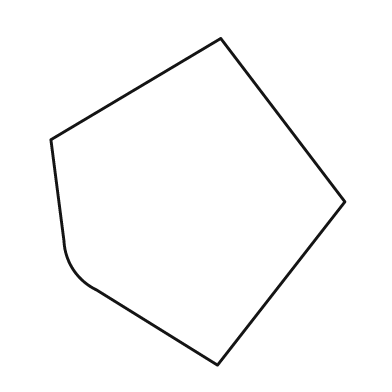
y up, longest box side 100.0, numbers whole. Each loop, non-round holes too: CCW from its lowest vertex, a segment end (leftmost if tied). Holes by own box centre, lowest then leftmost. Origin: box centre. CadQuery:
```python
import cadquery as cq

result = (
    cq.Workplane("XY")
    .moveTo(6.0, -50.0)
    .lineTo(45.0, 0.0)
    .lineTo(7.0, 50.0)
    .lineTo(-45.0, 19.0)
    .lineTo(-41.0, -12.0)
    .threePointArc((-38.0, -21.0), (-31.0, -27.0))
    .close()
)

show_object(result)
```